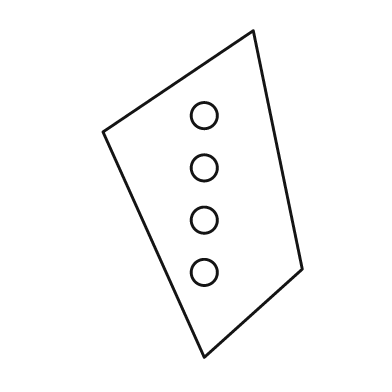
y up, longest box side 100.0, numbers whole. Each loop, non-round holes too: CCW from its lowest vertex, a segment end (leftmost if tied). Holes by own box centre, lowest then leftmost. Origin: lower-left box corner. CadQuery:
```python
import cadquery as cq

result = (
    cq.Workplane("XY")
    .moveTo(31.0, 0.0)
    .lineTo(61.0, 27.0)
    .lineTo(46.0, 100.0)
    .lineTo(0.0, 69.0)
    .close()
    .moveTo(31.0, 26.0)
    .circle(4.0)
    .moveTo(31.0, 42.0)
    .circle(4.0)
    .moveTo(31.0, 58.0)
    .circle(4.0)
    .moveTo(31.0, 74.0)
    .circle(4.0)
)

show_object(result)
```